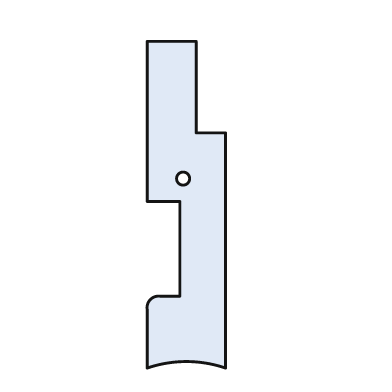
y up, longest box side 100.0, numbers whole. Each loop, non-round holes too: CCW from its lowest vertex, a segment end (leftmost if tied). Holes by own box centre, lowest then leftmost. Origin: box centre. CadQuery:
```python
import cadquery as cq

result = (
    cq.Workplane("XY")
    .moveTo(-12.0, -50.0)
    .threePointArc((0.0, -48.0), (12.0, -50.0))
    .lineTo(12.0, 22.0)
    .lineTo(3.0, 22.0)
    .lineTo(3.0, 50.0)
    .lineTo(-12.0, 50.0)
    .lineTo(-12.0, 1.0)
    .lineTo(-2.0, 1.0)
    .lineTo(-2.0, -28.0)
    .lineTo(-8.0, -28.0)
    .threePointArc((-11.0, -29.0), (-12.0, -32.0))
    .close()
    .moveTo(-1.0, 8.0)
    .circle(2.0)
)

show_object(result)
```